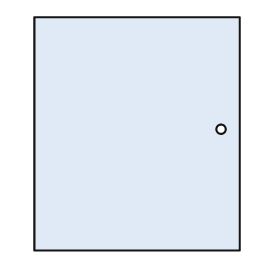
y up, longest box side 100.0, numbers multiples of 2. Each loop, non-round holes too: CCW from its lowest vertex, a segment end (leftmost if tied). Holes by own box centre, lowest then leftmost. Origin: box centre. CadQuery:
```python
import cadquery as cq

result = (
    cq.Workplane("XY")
    .moveTo(-44.0, -50.0)
    .lineTo(44.0, -50.0)
    .lineTo(44.0, 50.0)
    .lineTo(-44.0, 50.0)
    .close()
    .moveTo(36.0, 2.0)
    .circle(2.0)
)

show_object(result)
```